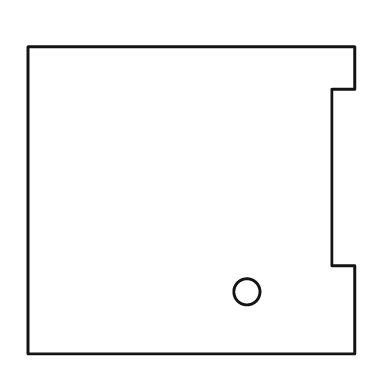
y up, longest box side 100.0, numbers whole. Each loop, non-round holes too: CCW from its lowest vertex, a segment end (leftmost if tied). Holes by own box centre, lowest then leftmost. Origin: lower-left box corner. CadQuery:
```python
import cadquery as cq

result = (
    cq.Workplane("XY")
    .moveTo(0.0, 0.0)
    .lineTo(100.0, 0.0)
    .lineTo(100.0, 27.0)
    .lineTo(93.0, 27.0)
    .lineTo(93.0, 81.0)
    .lineTo(100.0, 81.0)
    .lineTo(100.0, 94.0)
    .lineTo(0.0, 94.0)
    .close()
    .moveTo(67.0, 19.0)
    .circle(4.0)
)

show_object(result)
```